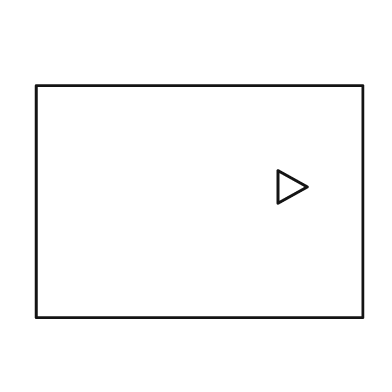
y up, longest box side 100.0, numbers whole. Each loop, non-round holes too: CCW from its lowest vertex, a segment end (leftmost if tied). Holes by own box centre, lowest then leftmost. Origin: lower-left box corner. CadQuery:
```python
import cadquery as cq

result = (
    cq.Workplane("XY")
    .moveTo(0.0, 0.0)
    .lineTo(100.0, 0.0)
    .lineTo(100.0, 71.0)
    .lineTo(0.0, 71.0)
    .close()
    .moveTo(74.0, 35.0)
    .lineTo(83.0, 40.0)
    .lineTo(74.0, 45.0)
    .close()
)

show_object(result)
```